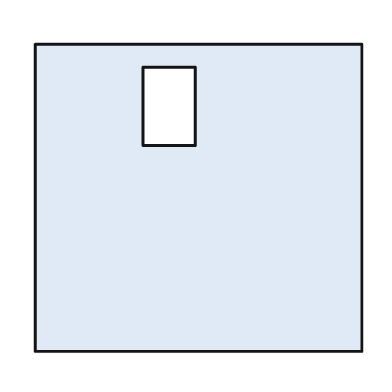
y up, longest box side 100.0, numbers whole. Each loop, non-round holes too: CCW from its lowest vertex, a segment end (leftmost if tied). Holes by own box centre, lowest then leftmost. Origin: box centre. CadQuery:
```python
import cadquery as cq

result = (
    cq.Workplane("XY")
    .moveTo(-50.0, -47.0)
    .lineTo(50.0, -47.0)
    .lineTo(50.0, 47.0)
    .lineTo(-50.0, 47.0)
    .close()
    .moveTo(-17.0, 16.0)
    .lineTo(-1.0, 16.0)
    .lineTo(-1.0, 40.0)
    .lineTo(-17.0, 40.0)
    .close()
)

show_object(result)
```